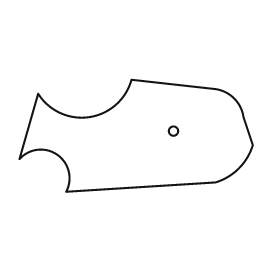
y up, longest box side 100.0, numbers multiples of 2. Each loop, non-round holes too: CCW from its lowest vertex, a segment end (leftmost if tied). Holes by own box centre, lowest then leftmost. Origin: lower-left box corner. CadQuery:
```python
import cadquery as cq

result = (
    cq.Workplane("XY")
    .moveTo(20.0, 0.0)
    .lineTo(84.0, 4.0)
    .threePointArc((94.0, 10.0), (100.0, 20.0))
    .lineTo(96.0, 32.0)
    .threePointArc((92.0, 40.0), (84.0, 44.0))
    .lineTo(48.0, 48.0)
    .threePointArc((30.0, 32.0), (8.0, 42.0))
    .lineTo(0.0, 14.0)
    .threePointArc((16.0, 16.0), (20.0, 0.0))
    .close()
    .moveTo(66.0, 26.0)
    .circle(2.0)
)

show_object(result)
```